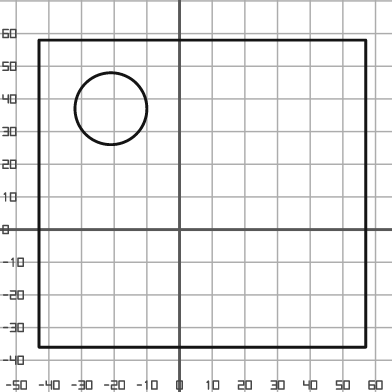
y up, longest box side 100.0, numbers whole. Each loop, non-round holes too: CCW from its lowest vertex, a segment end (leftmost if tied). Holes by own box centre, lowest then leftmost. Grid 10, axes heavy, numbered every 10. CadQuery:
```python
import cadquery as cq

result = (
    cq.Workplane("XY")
    .moveTo(-43.0, -36.0)
    .lineTo(57.0, -36.0)
    .lineTo(57.0, 58.0)
    .lineTo(-43.0, 58.0)
    .close()
    .moveTo(-21.0, 37.0)
    .circle(11.0)
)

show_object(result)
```